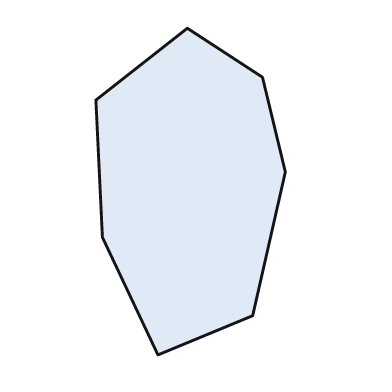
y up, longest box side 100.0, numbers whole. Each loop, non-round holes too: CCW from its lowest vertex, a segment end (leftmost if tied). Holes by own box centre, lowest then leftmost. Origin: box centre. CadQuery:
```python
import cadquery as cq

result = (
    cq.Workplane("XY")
    .moveTo(-10.0, -50.0)
    .lineTo(19.0, -38.0)
    .lineTo(29.0, 6.0)
    .lineTo(22.0, 35.0)
    .lineTo(-1.0, 50.0)
    .lineTo(-29.0, 28.0)
    .lineTo(-27.0, -14.0)
    .close()
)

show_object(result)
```